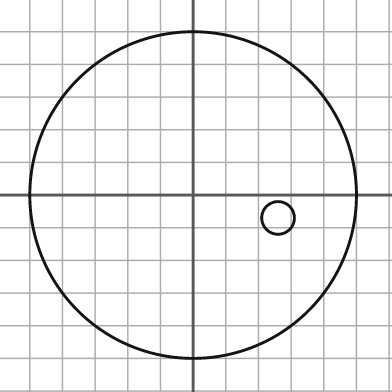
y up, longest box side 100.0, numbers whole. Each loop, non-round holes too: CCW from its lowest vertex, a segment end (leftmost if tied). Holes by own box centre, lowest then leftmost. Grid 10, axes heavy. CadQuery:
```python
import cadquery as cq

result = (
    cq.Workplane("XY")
    .moveTo(0.0, 0.0)
    .circle(50.0)
    .moveTo(26.0, -7.0)
    .circle(5.0)
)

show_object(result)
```